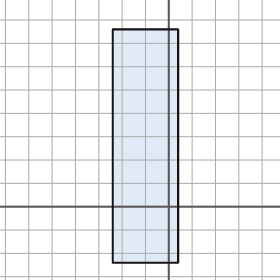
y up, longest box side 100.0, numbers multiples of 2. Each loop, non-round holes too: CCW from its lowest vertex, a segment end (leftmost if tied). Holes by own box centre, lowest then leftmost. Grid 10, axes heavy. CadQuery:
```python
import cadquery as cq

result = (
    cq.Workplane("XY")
    .moveTo(-24.0, -24.0)
    .lineTo(4.0, -24.0)
    .lineTo(4.0, 76.0)
    .lineTo(-24.0, 76.0)
    .close()
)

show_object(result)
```